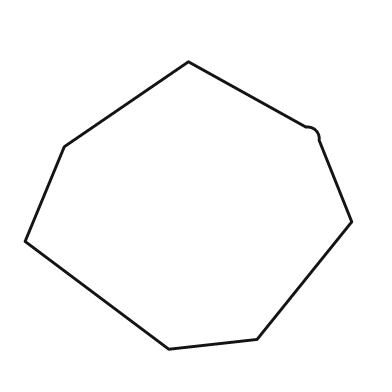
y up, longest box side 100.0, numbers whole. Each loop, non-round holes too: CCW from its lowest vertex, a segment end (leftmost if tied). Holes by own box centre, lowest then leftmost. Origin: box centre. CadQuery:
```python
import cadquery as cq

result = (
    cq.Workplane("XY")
    .moveTo(-6.0, -44.0)
    .lineTo(21.0, -41.0)
    .lineTo(50.0, -5.0)
    .lineTo(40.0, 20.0)
    .threePointArc((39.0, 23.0), (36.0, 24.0))
    .lineTo(0.0, 44.0)
    .lineTo(-38.0, 18.0)
    .lineTo(-50.0, -11.0)
    .close()
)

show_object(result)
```